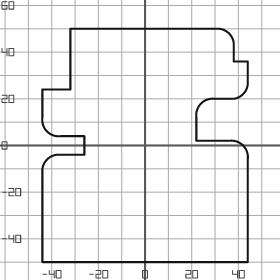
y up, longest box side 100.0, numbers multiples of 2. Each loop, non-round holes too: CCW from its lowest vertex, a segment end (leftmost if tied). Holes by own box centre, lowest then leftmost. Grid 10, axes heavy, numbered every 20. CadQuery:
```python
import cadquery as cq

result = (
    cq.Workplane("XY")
    .moveTo(-44.0, -50.0)
    .lineTo(44.0, -50.0)
    .lineTo(44.0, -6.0)
    .threePointArc((42.0, 0.0), (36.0, 2.0))
    .lineTo(22.0, 2.0)
    .lineTo(22.0, 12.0)
    .threePointArc((24.0, 18.0), (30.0, 20.0))
    .lineTo(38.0, 20.0)
    .threePointArc((42.0, 22.0), (44.0, 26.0))
    .lineTo(44.0, 36.0)
    .lineTo(38.0, 36.0)
    .lineTo(38.0, 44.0)
    .threePointArc((36.0, 48.0), (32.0, 50.0))
    .lineTo(-32.0, 50.0)
    .lineTo(-32.0, 24.0)
    .lineTo(-44.0, 24.0)
    .lineTo(-44.0, 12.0)
    .threePointArc((-42.0, 6.0), (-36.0, 4.0))
    .lineTo(-26.0, 4.0)
    .lineTo(-26.0, -4.0)
    .lineTo(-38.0, -4.0)
    .threePointArc((-42.0, -6.0), (-44.0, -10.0))
    .close()
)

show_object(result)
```